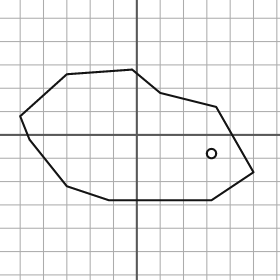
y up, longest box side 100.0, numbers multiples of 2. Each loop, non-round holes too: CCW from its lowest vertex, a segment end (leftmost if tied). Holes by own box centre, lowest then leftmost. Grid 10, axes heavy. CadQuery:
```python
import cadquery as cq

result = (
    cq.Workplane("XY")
    .moveTo(-12.0, -28.0)
    .lineTo(32.0, -28.0)
    .lineTo(50.0, -16.0)
    .lineTo(34.0, 12.0)
    .lineTo(10.0, 18.0)
    .lineTo(-2.0, 28.0)
    .lineTo(-30.0, 26.0)
    .lineTo(-50.0, 8.0)
    .lineTo(-46.0, -2.0)
    .lineTo(-30.0, -22.0)
    .close()
    .moveTo(32.0, -8.0)
    .circle(2.0)
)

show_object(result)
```